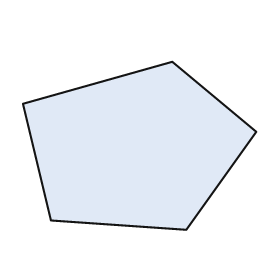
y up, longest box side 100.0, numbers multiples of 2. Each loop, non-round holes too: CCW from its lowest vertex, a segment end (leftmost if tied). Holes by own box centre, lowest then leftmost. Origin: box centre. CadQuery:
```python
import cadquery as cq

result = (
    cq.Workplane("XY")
    .moveTo(20.0, -36.0)
    .lineTo(50.0, 6.0)
    .lineTo(14.0, 36.0)
    .lineTo(-50.0, 18.0)
    .lineTo(-38.0, -32.0)
    .close()
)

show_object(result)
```